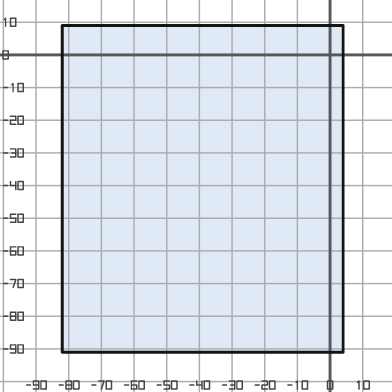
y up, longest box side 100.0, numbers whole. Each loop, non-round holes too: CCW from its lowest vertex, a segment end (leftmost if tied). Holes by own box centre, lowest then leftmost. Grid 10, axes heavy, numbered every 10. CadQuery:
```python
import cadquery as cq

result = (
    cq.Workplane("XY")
    .moveTo(-82.0, -91.0)
    .lineTo(4.0, -91.0)
    .lineTo(4.0, 9.0)
    .lineTo(-82.0, 9.0)
    .close()
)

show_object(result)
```